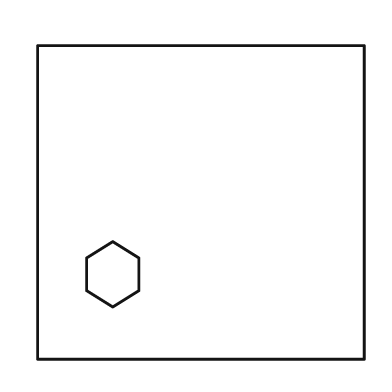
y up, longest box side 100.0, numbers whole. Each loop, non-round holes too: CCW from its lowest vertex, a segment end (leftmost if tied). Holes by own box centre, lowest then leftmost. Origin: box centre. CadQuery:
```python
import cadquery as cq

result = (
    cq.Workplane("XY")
    .moveTo(-50.0, -48.0)
    .lineTo(50.0, -48.0)
    .lineTo(50.0, 48.0)
    .lineTo(-50.0, 48.0)
    .close()
    .moveTo(-27.0, -32.0)
    .lineTo(-19.0, -27.0)
    .lineTo(-19.0, -17.0)
    .lineTo(-27.0, -12.0)
    .lineTo(-35.0, -17.0)
    .lineTo(-35.0, -27.0)
    .close()
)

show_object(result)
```